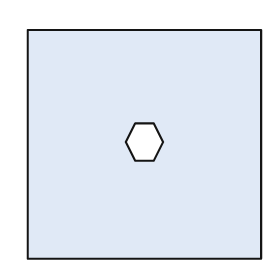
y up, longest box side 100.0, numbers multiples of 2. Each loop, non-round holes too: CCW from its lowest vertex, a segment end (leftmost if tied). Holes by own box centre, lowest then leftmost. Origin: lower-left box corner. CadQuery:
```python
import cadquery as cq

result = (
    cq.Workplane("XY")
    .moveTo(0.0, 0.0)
    .lineTo(100.0, 0.0)
    .lineTo(100.0, 98.0)
    .lineTo(0.0, 98.0)
    .close()
    .moveTo(46.0, 42.0)
    .lineTo(54.0, 42.0)
    .lineTo(58.0, 50.0)
    .lineTo(54.0, 58.0)
    .lineTo(46.0, 58.0)
    .lineTo(42.0, 50.0)
    .close()
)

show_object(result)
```